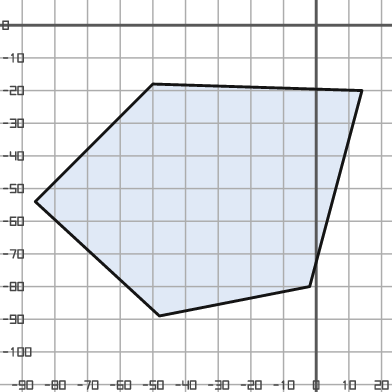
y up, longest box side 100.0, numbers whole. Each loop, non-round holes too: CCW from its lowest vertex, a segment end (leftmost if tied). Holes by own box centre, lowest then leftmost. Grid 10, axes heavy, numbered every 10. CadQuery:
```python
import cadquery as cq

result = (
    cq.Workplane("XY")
    .moveTo(-48.0, -89.0)
    .lineTo(-2.0, -80.0)
    .lineTo(14.0, -20.0)
    .lineTo(-50.0, -18.0)
    .lineTo(-86.0, -54.0)
    .close()
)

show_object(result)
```